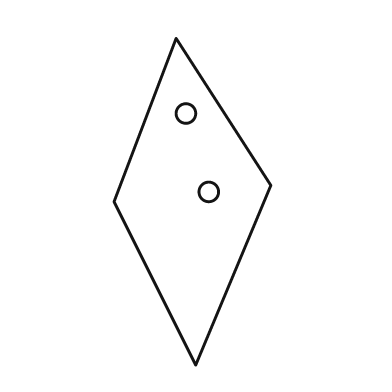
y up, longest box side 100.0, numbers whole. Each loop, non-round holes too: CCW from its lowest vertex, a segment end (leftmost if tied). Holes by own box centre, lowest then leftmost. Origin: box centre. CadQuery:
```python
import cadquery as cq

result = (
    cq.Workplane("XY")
    .moveTo(1.0, -50.0)
    .lineTo(24.0, 5.0)
    .lineTo(-5.0, 50.0)
    .lineTo(-24.0, 0.0)
    .close()
    .moveTo(5.0, 3.0)
    .circle(3.0)
    .moveTo(-2.0, 27.0)
    .circle(3.0)
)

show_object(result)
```